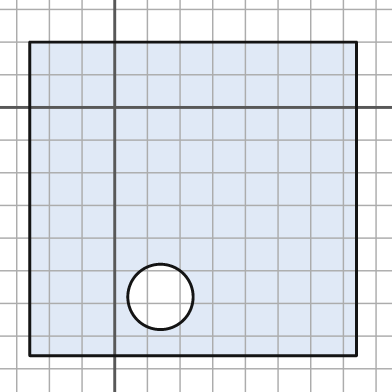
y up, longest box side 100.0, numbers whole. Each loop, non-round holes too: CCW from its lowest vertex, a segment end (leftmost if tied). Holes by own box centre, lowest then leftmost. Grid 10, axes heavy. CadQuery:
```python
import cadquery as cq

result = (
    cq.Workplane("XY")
    .moveTo(-26.0, -76.0)
    .lineTo(74.0, -76.0)
    .lineTo(74.0, 20.0)
    .lineTo(-26.0, 20.0)
    .close()
    .moveTo(14.0, -58.0)
    .circle(10.0)
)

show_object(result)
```